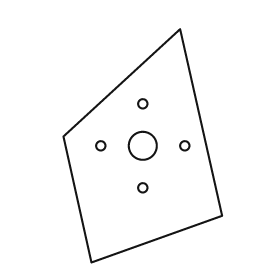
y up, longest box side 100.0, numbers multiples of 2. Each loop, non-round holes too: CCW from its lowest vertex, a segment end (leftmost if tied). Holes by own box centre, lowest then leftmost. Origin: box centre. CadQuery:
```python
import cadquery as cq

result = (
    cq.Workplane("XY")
    .moveTo(-22.0, -50.0)
    .lineTo(34.0, -30.0)
    .lineTo(16.0, 50.0)
    .lineTo(-34.0, 4.0)
    .close()
    .moveTo(0.0, -18.0)
    .circle(2.0)
    .moveTo(-18.0, 0.0)
    .circle(2.0)
    .moveTo(0.0, 0.0)
    .circle(6.0)
    .moveTo(18.0, 0.0)
    .circle(2.0)
    .moveTo(0.0, 18.0)
    .circle(2.0)
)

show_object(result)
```